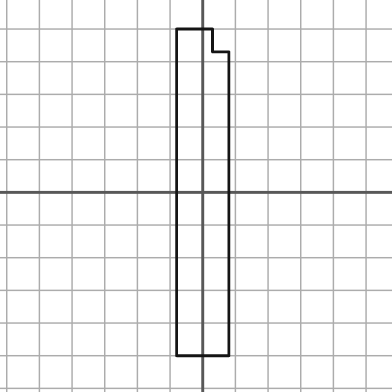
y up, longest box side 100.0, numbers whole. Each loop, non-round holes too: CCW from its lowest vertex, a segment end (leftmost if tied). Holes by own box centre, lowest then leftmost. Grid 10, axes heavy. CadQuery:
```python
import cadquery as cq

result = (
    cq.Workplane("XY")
    .moveTo(-8.0, -50.0)
    .lineTo(8.0, -50.0)
    .lineTo(8.0, 43.0)
    .lineTo(3.0, 43.0)
    .lineTo(3.0, 50.0)
    .lineTo(-8.0, 50.0)
    .close()
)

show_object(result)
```